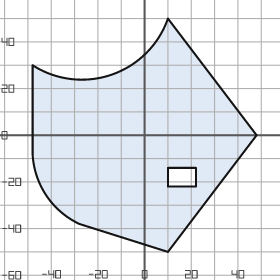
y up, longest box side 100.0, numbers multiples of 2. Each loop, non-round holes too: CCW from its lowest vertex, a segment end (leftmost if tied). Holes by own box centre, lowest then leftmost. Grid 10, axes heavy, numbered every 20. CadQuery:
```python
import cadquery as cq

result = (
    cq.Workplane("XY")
    .moveTo(10.0, -50.0)
    .lineTo(48.0, 0.0)
    .lineTo(10.0, 50.0)
    .threePointArc((-14.0, 26.0), (-48.0, 30.0))
    .lineTo(-48.0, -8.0)
    .threePointArc((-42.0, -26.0), (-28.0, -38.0))
    .close()
    .moveTo(10.0, -22.0)
    .lineTo(22.0, -22.0)
    .lineTo(22.0, -14.0)
    .lineTo(10.0, -14.0)
    .close()
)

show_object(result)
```